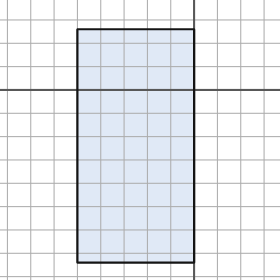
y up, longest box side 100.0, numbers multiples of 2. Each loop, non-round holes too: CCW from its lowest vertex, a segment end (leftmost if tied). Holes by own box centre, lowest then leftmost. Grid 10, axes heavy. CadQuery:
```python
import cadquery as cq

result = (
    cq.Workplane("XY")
    .moveTo(-50.0, -74.0)
    .lineTo(0.0, -74.0)
    .lineTo(0.0, 26.0)
    .lineTo(-50.0, 26.0)
    .close()
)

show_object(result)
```